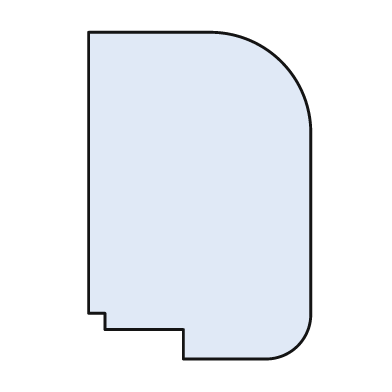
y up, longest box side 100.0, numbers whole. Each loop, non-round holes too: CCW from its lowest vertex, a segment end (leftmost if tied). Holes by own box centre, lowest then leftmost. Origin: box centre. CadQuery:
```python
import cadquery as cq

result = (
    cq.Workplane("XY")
    .moveTo(-5.0, -50.0)
    .lineTo(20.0, -50.0)
    .threePointArc((30.0, -46.0), (34.0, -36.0))
    .lineTo(34.0, 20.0)
    .threePointArc((25.0, 41.0), (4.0, 50.0))
    .lineTo(-34.0, 50.0)
    .lineTo(-34.0, -36.0)
    .lineTo(-29.0, -36.0)
    .lineTo(-29.0, -41.0)
    .lineTo(-5.0, -41.0)
    .close()
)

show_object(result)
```